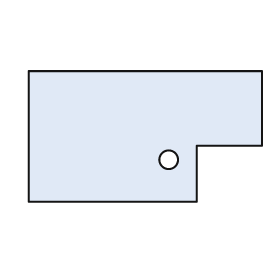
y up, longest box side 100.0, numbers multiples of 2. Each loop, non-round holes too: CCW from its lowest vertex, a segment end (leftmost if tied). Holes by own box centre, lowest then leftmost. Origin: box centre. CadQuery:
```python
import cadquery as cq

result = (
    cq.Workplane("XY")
    .moveTo(-50.0, -28.0)
    .lineTo(22.0, -28.0)
    .lineTo(22.0, -4.0)
    .lineTo(50.0, -4.0)
    .lineTo(50.0, 28.0)
    .lineTo(-50.0, 28.0)
    .close()
    .moveTo(10.0, -10.0)
    .circle(4.0)
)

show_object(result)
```